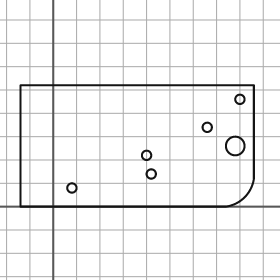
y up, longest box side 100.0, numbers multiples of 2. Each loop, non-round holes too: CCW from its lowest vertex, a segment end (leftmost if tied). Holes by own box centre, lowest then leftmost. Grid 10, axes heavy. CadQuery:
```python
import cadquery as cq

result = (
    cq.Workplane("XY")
    .moveTo(-14.0, 0.0)
    .lineTo(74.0, 0.0)
    .threePointArc((82.0, 4.0), (86.0, 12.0))
    .lineTo(86.0, 52.0)
    .lineTo(-14.0, 52.0)
    .close()
    .moveTo(8.0, 8.0)
    .circle(2.0)
    .moveTo(42.0, 14.0)
    .circle(2.0)
    .moveTo(40.0, 22.0)
    .circle(2.0)
    .moveTo(78.0, 26.0)
    .circle(4.0)
    .moveTo(66.0, 34.0)
    .circle(2.0)
    .moveTo(80.0, 46.0)
    .circle(2.0)
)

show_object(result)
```